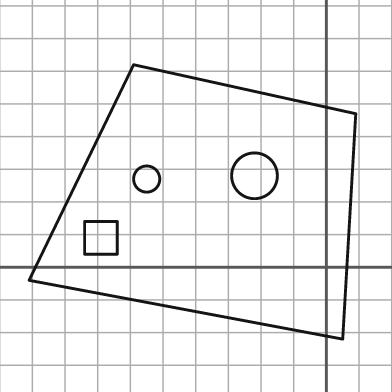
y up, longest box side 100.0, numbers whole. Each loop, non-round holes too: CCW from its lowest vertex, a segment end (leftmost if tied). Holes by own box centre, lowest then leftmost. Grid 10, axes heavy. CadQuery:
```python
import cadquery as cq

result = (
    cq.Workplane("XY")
    .moveTo(5.0, -22.0)
    .lineTo(9.0, 47.0)
    .lineTo(-59.0, 62.0)
    .lineTo(-91.0, -4.0)
    .close()
    .moveTo(-74.0, 4.0)
    .lineTo(-64.0, 4.0)
    .lineTo(-64.0, 14.0)
    .lineTo(-74.0, 14.0)
    .close()
    .moveTo(-55.0, 27.0)
    .circle(4.0)
    .moveTo(-22.0, 28.0)
    .circle(7.0)
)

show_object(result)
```